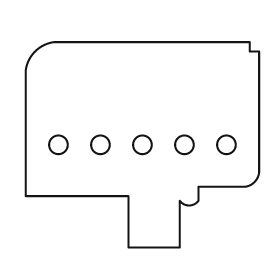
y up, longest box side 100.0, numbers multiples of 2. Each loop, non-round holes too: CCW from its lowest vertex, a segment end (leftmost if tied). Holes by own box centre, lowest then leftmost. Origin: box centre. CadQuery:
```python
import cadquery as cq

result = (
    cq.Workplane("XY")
    .moveTo(-6.0, -44.0)
    .lineTo(16.0, -44.0)
    .lineTo(16.0, -24.0)
    .threePointArc((20.0, -26.0), (24.0, -24.0))
    .lineTo(24.0, -18.0)
    .lineTo(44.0, -18.0)
    .threePointArc((48.0, -16.0), (50.0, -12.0))
    .lineTo(50.0, 40.0)
    .lineTo(46.0, 40.0)
    .lineTo(46.0, 44.0)
    .lineTo(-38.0, 44.0)
    .threePointArc((-46.0, 40.0), (-50.0, 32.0))
    .lineTo(-50.0, -22.0)
    .lineTo(-6.0, -22.0)
    .close()
    .moveTo(-36.0, 0.0)
    .circle(4.0)
    .moveTo(-18.0, 0.0)
    .circle(4.0)
    .moveTo(0.0, 0.0)
    .circle(4.0)
    .moveTo(18.0, 0.0)
    .circle(4.0)
    .moveTo(36.0, 0.0)
    .circle(4.0)
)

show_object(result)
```